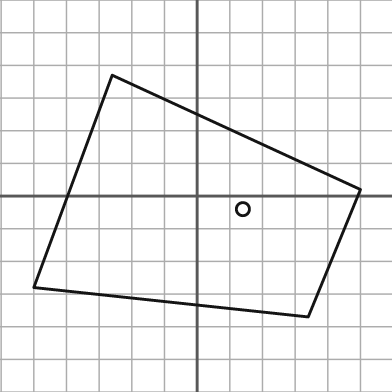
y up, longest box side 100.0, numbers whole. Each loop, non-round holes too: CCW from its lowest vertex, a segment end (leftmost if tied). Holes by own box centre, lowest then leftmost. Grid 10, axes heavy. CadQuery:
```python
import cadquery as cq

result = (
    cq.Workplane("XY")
    .moveTo(34.0, -37.0)
    .lineTo(50.0, 2.0)
    .lineTo(-26.0, 37.0)
    .lineTo(-50.0, -28.0)
    .close()
    .moveTo(14.0, -4.0)
    .circle(2.0)
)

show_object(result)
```